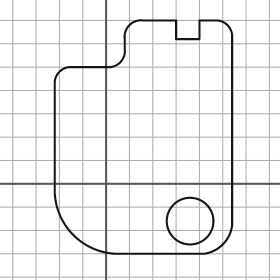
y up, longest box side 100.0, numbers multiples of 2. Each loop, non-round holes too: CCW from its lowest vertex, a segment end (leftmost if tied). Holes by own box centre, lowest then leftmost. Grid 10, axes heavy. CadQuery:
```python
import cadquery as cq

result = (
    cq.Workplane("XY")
    .moveTo(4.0, -30.0)
    .lineTo(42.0, -30.0)
    .threePointArc((50.0, -26.0), (54.0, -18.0))
    .lineTo(54.0, 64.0)
    .threePointArc((52.0, 68.0), (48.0, 70.0))
    .lineTo(40.0, 70.0)
    .lineTo(40.0, 62.0)
    .lineTo(30.0, 62.0)
    .lineTo(30.0, 70.0)
    .lineTo(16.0, 70.0)
    .threePointArc((10.0, 68.0), (8.0, 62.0))
    .lineTo(8.0, 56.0)
    .threePointArc((6.0, 52.0), (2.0, 50.0))
    .lineTo(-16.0, 50.0)
    .threePointArc((-20.0, 48.0), (-22.0, 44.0))
    .lineTo(-22.0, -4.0)
    .threePointArc((-14.0, -22.0), (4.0, -30.0))
    .close()
    .moveTo(36.0, -16.0)
    .circle(10.0)
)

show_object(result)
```